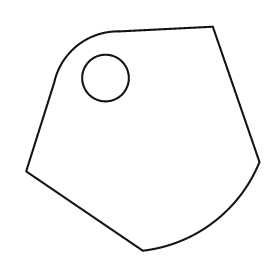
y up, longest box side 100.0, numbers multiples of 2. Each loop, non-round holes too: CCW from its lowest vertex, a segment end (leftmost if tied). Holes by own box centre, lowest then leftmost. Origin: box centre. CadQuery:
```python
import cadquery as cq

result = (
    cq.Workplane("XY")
    .moveTo(0.0, -48.0)
    .threePointArc((30.0, -36.0), (50.0, -10.0))
    .lineTo(30.0, 48.0)
    .lineTo(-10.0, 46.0)
    .threePointArc((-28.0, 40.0), (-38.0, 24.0))
    .lineTo(-50.0, -14.0)
    .close()
    .moveTo(-16.0, 26.0)
    .circle(10.0)
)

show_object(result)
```